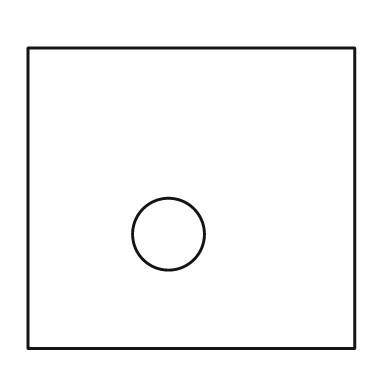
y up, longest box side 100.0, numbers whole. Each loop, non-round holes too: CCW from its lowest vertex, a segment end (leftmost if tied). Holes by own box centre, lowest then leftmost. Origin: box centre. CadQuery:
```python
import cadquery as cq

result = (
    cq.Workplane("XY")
    .moveTo(-50.0, -46.0)
    .lineTo(50.0, -46.0)
    .lineTo(50.0, 46.0)
    .lineTo(-50.0, 46.0)
    .close()
    .moveTo(-7.0, -11.0)
    .circle(11.0)
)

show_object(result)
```